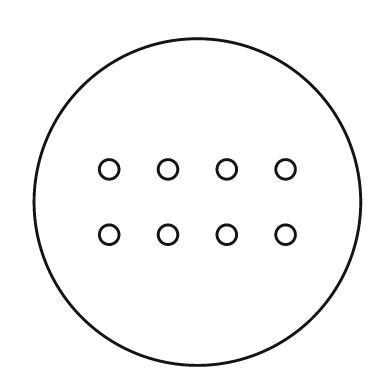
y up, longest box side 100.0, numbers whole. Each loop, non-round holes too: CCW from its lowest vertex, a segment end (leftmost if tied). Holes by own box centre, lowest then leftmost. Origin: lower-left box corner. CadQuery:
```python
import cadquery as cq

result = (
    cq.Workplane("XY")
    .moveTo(50.0, 50.0)
    .circle(50.0)
    .moveTo(23.0, 40.0)
    .circle(3.0)
    .moveTo(41.0, 40.0)
    .circle(3.0)
    .moveTo(59.0, 40.0)
    .circle(3.0)
    .moveTo(77.0, 40.0)
    .circle(3.0)
    .moveTo(23.0, 60.0)
    .circle(3.0)
    .moveTo(41.0, 60.0)
    .circle(3.0)
    .moveTo(59.0, 60.0)
    .circle(3.0)
    .moveTo(77.0, 60.0)
    .circle(3.0)
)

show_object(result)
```